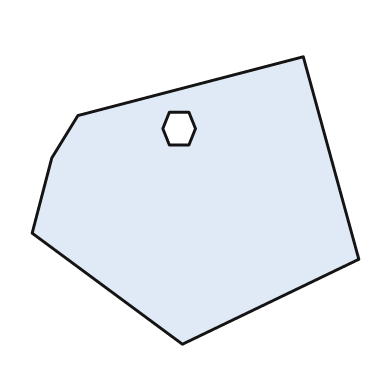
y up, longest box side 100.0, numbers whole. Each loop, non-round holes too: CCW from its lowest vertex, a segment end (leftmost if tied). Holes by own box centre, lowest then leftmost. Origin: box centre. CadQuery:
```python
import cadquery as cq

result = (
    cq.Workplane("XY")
    .moveTo(-4.0, -44.0)
    .lineTo(50.0, -18.0)
    .lineTo(33.0, 44.0)
    .lineTo(-36.0, 26.0)
    .lineTo(-44.0, 13.0)
    .lineTo(-50.0, -10.0)
    .close()
    .moveTo(-8.0, 17.0)
    .lineTo(-2.0, 17.0)
    .lineTo(0.0, 22.0)
    .lineTo(-2.0, 27.0)
    .lineTo(-8.0, 27.0)
    .lineTo(-10.0, 22.0)
    .close()
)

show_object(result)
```